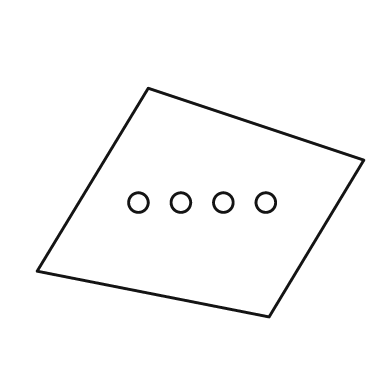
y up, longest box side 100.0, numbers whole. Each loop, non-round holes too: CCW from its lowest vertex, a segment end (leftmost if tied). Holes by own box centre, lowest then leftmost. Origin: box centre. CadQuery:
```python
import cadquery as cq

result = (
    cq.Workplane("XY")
    .moveTo(21.0, -35.0)
    .lineTo(50.0, 13.0)
    .lineTo(-16.0, 35.0)
    .lineTo(-50.0, -21.0)
    .close()
    .moveTo(-19.0, 0.0)
    .circle(3.0)
    .moveTo(-6.0, 0.0)
    .circle(3.0)
    .moveTo(7.0, 0.0)
    .circle(3.0)
    .moveTo(20.0, 0.0)
    .circle(3.0)
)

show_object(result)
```